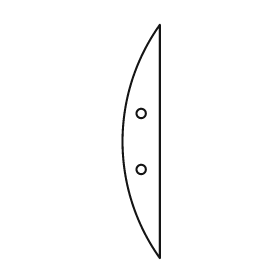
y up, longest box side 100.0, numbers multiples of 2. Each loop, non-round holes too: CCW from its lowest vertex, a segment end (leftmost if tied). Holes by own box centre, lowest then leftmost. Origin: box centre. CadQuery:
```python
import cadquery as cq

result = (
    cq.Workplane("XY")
    .moveTo(8.0, -50.0)
    .lineTo(8.0, 50.0)
    .threePointArc((-8.0, 0.0), (8.0, -50.0))
    .close()
    .moveTo(0.0, -12.0)
    .circle(2.0)
    .moveTo(0.0, 12.0)
    .circle(2.0)
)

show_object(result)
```